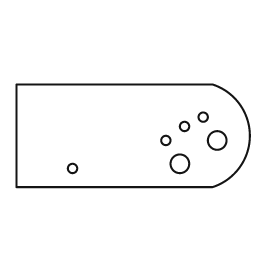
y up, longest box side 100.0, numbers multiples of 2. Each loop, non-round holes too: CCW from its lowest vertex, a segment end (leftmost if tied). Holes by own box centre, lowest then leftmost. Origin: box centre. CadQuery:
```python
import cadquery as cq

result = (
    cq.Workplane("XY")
    .moveTo(-50.0, -22.0)
    .lineTo(34.0, -22.0)
    .threePointArc((50.0, 0.0), (34.0, 22.0))
    .lineTo(-50.0, 22.0)
    .close()
    .moveTo(-26.0, -14.0)
    .circle(2.0)
    .moveTo(20.0, -12.0)
    .circle(4.0)
    .moveTo(14.0, -2.0)
    .circle(2.0)
    .moveTo(36.0, -2.0)
    .circle(4.0)
    .moveTo(22.0, 4.0)
    .circle(2.0)
    .moveTo(30.0, 8.0)
    .circle(2.0)
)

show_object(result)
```